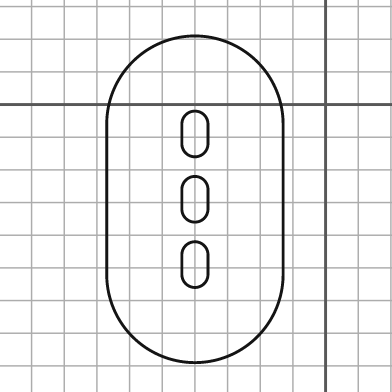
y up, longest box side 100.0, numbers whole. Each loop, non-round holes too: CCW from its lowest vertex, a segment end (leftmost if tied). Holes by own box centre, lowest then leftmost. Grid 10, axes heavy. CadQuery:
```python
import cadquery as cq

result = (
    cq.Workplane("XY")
    .moveTo(-67.0, -52.0)
    .threePointArc((-40.0, -79.0), (-13.0, -52.0))
    .lineTo(-13.0, -6.0)
    .threePointArc((-40.0, 21.0), (-67.0, -6.0))
    .close()
    .moveTo(-44.0, -52.0)
    .threePointArc((-40.0, -56.0), (-36.0, -52.0))
    .lineTo(-36.0, -46.0)
    .threePointArc((-40.0, -42.0), (-44.0, -46.0))
    .close()
    .moveTo(-44.0, -32.0)
    .threePointArc((-40.0, -36.0), (-36.0, -32.0))
    .lineTo(-36.0, -26.0)
    .threePointArc((-40.0, -22.0), (-44.0, -26.0))
    .close()
    .moveTo(-44.0, -12.0)
    .threePointArc((-40.0, -16.0), (-36.0, -12.0))
    .lineTo(-36.0, -6.0)
    .threePointArc((-40.0, -2.0), (-44.0, -6.0))
    .close()
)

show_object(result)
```